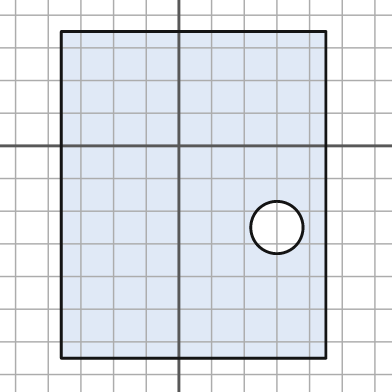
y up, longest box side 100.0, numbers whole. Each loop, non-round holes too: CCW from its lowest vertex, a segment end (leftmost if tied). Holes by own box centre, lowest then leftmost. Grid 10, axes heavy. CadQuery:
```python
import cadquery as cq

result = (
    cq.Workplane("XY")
    .moveTo(-36.0, -65.0)
    .lineTo(45.0, -65.0)
    .lineTo(45.0, 35.0)
    .lineTo(-36.0, 35.0)
    .close()
    .moveTo(30.0, -25.0)
    .circle(8.0)
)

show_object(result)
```